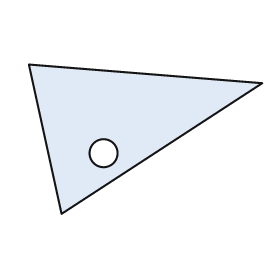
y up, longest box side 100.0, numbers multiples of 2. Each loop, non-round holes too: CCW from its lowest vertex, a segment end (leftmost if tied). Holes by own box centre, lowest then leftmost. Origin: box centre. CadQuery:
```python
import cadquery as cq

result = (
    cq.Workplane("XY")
    .moveTo(-36.0, -32.0)
    .lineTo(50.0, 24.0)
    .lineTo(-50.0, 32.0)
    .close()
    .moveTo(-18.0, -6.0)
    .circle(6.0)
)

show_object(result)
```